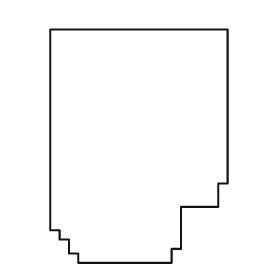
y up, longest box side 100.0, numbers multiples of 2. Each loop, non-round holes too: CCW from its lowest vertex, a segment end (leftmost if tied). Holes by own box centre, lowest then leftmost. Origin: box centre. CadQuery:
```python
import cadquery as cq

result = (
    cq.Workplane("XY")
    .moveTo(-26.0, -50.0)
    .lineTo(14.0, -50.0)
    .lineTo(14.0, -44.0)
    .lineTo(18.0, -44.0)
    .lineTo(18.0, -26.0)
    .lineTo(34.0, -26.0)
    .lineTo(34.0, -16.0)
    .lineTo(38.0, -16.0)
    .lineTo(38.0, 50.0)
    .lineTo(-38.0, 50.0)
    .lineTo(-38.0, -36.0)
    .lineTo(-34.0, -36.0)
    .lineTo(-34.0, -40.0)
    .lineTo(-30.0, -40.0)
    .lineTo(-30.0, -46.0)
    .lineTo(-26.0, -46.0)
    .close()
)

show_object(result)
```